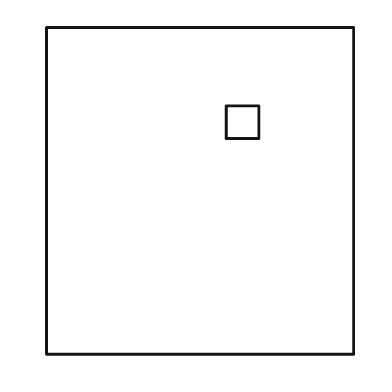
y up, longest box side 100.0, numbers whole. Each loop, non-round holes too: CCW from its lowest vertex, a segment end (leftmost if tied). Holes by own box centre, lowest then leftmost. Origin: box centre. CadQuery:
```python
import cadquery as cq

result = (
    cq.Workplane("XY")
    .moveTo(-47.0, -50.0)
    .lineTo(47.0, -50.0)
    .lineTo(47.0, 50.0)
    .lineTo(-47.0, 50.0)
    .close()
    .moveTo(8.0, 16.0)
    .lineTo(18.0, 16.0)
    .lineTo(18.0, 26.0)
    .lineTo(8.0, 26.0)
    .close()
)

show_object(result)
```